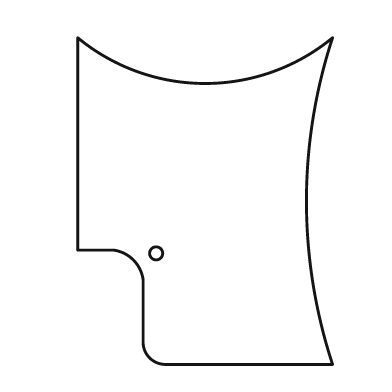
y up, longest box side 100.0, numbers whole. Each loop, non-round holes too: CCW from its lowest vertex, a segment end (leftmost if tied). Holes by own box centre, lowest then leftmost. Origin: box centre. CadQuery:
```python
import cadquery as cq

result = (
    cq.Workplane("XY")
    .moveTo(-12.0, -50.0)
    .lineTo(39.0, -50.0)
    .threePointArc((31.0, 0.0), (39.0, 50.0))
    .threePointArc((0.0, 36.0), (-39.0, 50.0))
    .lineTo(-39.0, -15.0)
    .lineTo(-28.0, -15.0)
    .threePointArc((-22.0, -18.0), (-19.0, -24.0))
    .lineTo(-19.0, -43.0)
    .threePointArc((-17.0, -48.0), (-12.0, -50.0))
    .close()
    .moveTo(-15.0, -16.0)
    .circle(2.0)
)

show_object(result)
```